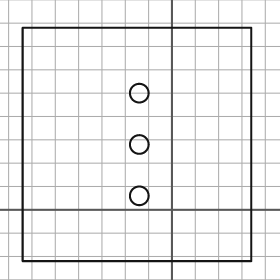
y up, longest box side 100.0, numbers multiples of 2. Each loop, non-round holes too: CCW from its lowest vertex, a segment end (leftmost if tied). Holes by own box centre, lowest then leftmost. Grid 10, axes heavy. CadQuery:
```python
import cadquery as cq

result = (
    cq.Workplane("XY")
    .moveTo(-64.0, -22.0)
    .lineTo(34.0, -22.0)
    .lineTo(34.0, 78.0)
    .lineTo(-64.0, 78.0)
    .close()
    .moveTo(-14.0, 6.0)
    .circle(4.0)
    .moveTo(-14.0, 28.0)
    .circle(4.0)
    .moveTo(-14.0, 50.0)
    .circle(4.0)
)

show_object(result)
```